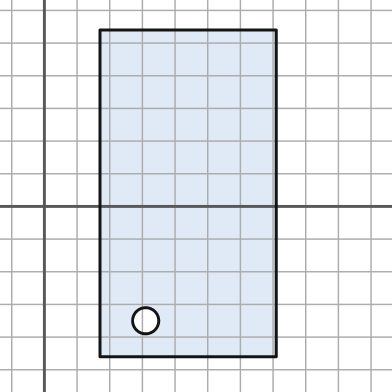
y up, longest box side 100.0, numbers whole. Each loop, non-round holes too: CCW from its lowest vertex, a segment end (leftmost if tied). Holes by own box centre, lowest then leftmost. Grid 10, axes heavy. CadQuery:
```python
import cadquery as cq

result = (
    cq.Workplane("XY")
    .moveTo(17.0, -46.0)
    .lineTo(71.0, -46.0)
    .lineTo(71.0, 54.0)
    .lineTo(17.0, 54.0)
    .close()
    .moveTo(31.0, -35.0)
    .circle(4.0)
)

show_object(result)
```